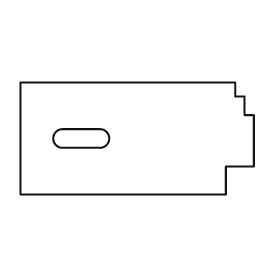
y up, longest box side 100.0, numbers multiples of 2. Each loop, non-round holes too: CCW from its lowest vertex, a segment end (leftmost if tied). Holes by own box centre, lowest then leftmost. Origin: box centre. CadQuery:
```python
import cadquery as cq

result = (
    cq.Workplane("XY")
    .moveTo(-50.0, -24.0)
    .lineTo(38.0, -24.0)
    .lineTo(38.0, -12.0)
    .lineTo(50.0, -12.0)
    .lineTo(50.0, 10.0)
    .lineTo(46.0, 10.0)
    .lineTo(46.0, 18.0)
    .lineTo(42.0, 18.0)
    .lineTo(42.0, 24.0)
    .lineTo(-50.0, 24.0)
    .close()
    .moveTo(-32.0, -4.0)
    .lineTo(-16.0, -4.0)
    .threePointArc((-12.0, 0.0), (-16.0, 4.0))
    .lineTo(-32.0, 4.0)
    .threePointArc((-36.0, 0.0), (-32.0, -4.0))
    .close()
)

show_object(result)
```